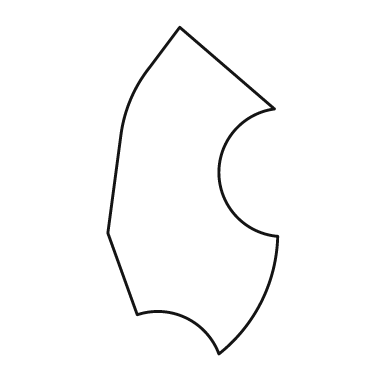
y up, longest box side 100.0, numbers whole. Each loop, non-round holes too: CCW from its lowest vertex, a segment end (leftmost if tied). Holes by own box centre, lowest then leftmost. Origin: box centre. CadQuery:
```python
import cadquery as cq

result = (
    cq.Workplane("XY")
    .moveTo(8.0, -50.0)
    .threePointArc((21.0, -34.0), (26.0, -14.0))
    .threePointArc((8.0, 5.0), (25.0, 25.0))
    .lineTo(-4.0, 50.0)
    .lineTo(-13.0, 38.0)
    .threePointArc((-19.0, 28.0), (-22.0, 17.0))
    .lineTo(-26.0, -13.0)
    .lineTo(-17.0, -38.0)
    .threePointArc((-2.0, -39.0), (8.0, -50.0))
    .close()
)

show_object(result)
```